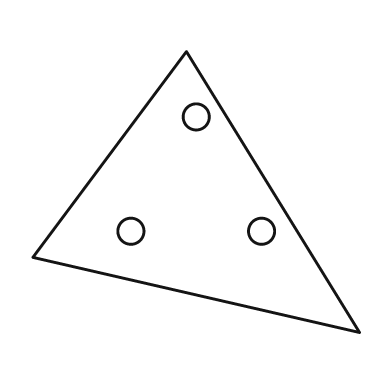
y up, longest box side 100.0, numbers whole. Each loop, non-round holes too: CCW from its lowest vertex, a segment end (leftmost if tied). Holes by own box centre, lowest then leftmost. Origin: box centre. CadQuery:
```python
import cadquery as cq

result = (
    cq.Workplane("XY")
    .moveTo(50.0, -43.0)
    .lineTo(-3.0, 43.0)
    .lineTo(-50.0, -20.0)
    .close()
    .moveTo(-20.0, -12.0)
    .circle(4.0)
    .moveTo(20.0, -12.0)
    .circle(4.0)
    .moveTo(0.0, 23.0)
    .circle(4.0)
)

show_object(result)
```